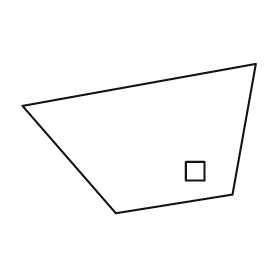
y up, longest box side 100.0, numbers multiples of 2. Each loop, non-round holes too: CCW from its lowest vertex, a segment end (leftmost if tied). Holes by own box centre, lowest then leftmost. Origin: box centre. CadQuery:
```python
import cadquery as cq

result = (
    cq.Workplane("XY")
    .moveTo(-10.0, -32.0)
    .lineTo(40.0, -24.0)
    .lineTo(50.0, 32.0)
    .lineTo(-50.0, 14.0)
    .close()
    .moveTo(20.0, -18.0)
    .lineTo(28.0, -18.0)
    .lineTo(28.0, -10.0)
    .lineTo(20.0, -10.0)
    .close()
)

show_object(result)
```